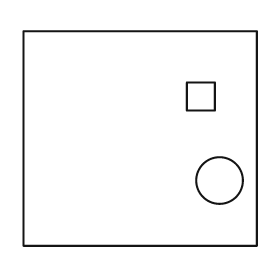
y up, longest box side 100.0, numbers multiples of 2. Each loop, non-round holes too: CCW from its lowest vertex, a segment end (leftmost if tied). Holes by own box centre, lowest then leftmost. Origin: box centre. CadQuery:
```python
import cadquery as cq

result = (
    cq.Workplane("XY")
    .moveTo(-50.0, -46.0)
    .lineTo(50.0, -46.0)
    .lineTo(50.0, 46.0)
    .lineTo(-50.0, 46.0)
    .close()
    .moveTo(34.0, -18.0)
    .circle(10.0)
    .moveTo(20.0, 12.0)
    .lineTo(32.0, 12.0)
    .lineTo(32.0, 24.0)
    .lineTo(20.0, 24.0)
    .close()
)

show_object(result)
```